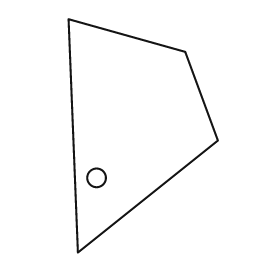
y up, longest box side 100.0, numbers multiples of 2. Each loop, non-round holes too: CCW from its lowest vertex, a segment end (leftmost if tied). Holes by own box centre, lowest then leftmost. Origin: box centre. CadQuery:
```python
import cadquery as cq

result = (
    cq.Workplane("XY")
    .moveTo(-28.0, -50.0)
    .lineTo(32.0, -2.0)
    .lineTo(18.0, 36.0)
    .lineTo(-32.0, 50.0)
    .close()
    .moveTo(-20.0, -18.0)
    .circle(4.0)
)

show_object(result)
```